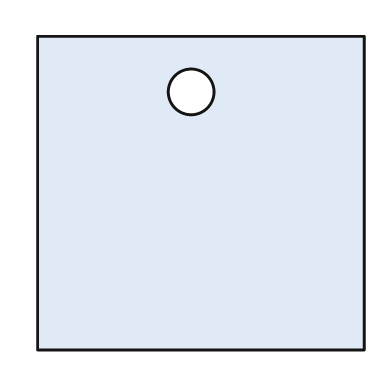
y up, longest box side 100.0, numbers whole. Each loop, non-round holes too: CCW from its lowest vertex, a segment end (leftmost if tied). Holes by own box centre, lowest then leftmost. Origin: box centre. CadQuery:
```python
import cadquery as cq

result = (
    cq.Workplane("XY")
    .moveTo(-50.0, -48.0)
    .lineTo(50.0, -48.0)
    .lineTo(50.0, 48.0)
    .lineTo(-50.0, 48.0)
    .close()
    .moveTo(-3.0, 31.0)
    .circle(7.0)
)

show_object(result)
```